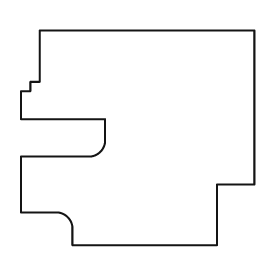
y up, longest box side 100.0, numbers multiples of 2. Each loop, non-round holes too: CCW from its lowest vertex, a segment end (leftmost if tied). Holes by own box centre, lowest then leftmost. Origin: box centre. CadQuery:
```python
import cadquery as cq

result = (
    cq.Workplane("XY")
    .moveTo(-28.0, -46.0)
    .lineTo(34.0, -46.0)
    .lineTo(34.0, -20.0)
    .lineTo(50.0, -20.0)
    .lineTo(50.0, 46.0)
    .lineTo(-42.0, 46.0)
    .lineTo(-42.0, 24.0)
    .lineTo(-46.0, 24.0)
    .lineTo(-46.0, 20.0)
    .lineTo(-50.0, 20.0)
    .lineTo(-50.0, 8.0)
    .lineTo(-14.0, 8.0)
    .lineTo(-14.0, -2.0)
    .threePointArc((-16.0, -6.0), (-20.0, -8.0))
    .lineTo(-50.0, -8.0)
    .lineTo(-50.0, -32.0)
    .lineTo(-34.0, -32.0)
    .threePointArc((-30.0, -34.0), (-28.0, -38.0))
    .close()
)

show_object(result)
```